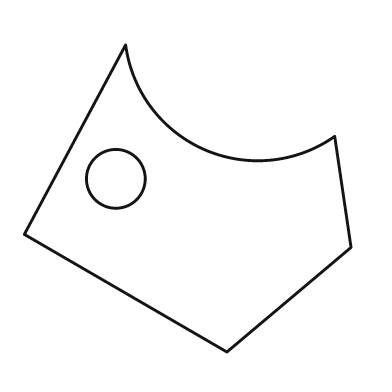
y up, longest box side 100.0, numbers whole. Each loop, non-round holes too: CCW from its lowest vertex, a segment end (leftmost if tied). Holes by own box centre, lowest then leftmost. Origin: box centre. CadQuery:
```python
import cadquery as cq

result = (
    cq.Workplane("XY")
    .moveTo(12.0, -47.0)
    .lineTo(50.0, -15.0)
    .lineTo(45.0, 19.0)
    .threePointArc((5.0, 15.0), (-19.0, 47.0))
    .lineTo(-50.0, -11.0)
    .close()
    .moveTo(-22.0, 6.0)
    .circle(9.0)
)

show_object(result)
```